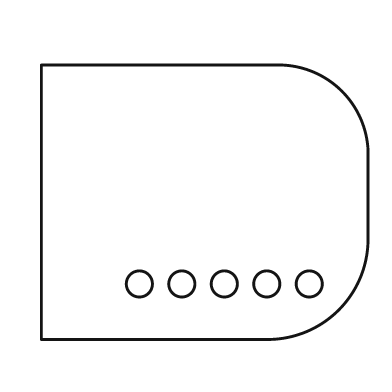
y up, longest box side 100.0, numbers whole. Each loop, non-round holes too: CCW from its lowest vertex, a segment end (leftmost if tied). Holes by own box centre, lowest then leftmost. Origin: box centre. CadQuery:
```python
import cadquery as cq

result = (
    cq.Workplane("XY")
    .moveTo(-50.0, -42.0)
    .lineTo(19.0, -42.0)
    .threePointArc((41.0, -33.0), (50.0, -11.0))
    .lineTo(50.0, 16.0)
    .threePointArc((42.0, 34.0), (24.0, 42.0))
    .lineTo(-50.0, 42.0)
    .close()
    .moveTo(-20.0, -25.0)
    .circle(4.0)
    .moveTo(-7.0, -25.0)
    .circle(4.0)
    .moveTo(6.0, -25.0)
    .circle(4.0)
    .moveTo(19.0, -25.0)
    .circle(4.0)
    .moveTo(32.0, -25.0)
    .circle(4.0)
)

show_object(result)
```